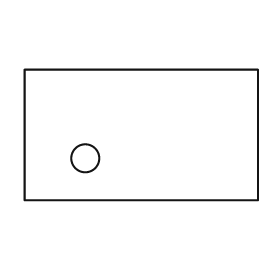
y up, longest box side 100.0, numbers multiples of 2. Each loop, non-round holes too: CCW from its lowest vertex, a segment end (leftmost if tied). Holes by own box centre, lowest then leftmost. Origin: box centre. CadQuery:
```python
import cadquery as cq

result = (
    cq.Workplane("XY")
    .moveTo(-50.0, -28.0)
    .lineTo(50.0, -28.0)
    .lineTo(50.0, 28.0)
    .lineTo(-50.0, 28.0)
    .close()
    .moveTo(-24.0, -10.0)
    .circle(6.0)
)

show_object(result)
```